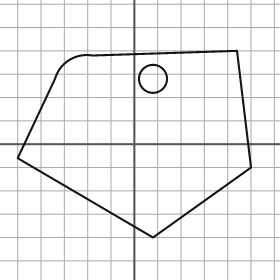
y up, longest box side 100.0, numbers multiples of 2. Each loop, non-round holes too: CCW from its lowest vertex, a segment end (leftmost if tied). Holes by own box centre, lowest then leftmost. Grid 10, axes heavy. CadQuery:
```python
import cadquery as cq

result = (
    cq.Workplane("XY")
    .moveTo(8.0, -40.0)
    .lineTo(50.0, -10.0)
    .lineTo(44.0, 40.0)
    .lineTo(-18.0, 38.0)
    .threePointArc((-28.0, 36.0), (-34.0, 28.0))
    .lineTo(-50.0, -6.0)
    .close()
    .moveTo(8.0, 28.0)
    .circle(6.0)
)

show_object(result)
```